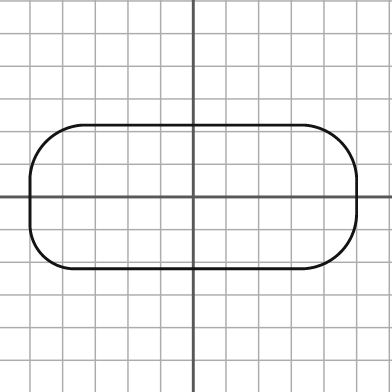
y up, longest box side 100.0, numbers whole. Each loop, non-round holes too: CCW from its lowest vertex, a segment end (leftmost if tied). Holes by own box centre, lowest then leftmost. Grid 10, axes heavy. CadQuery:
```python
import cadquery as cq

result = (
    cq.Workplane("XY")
    .moveTo(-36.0, -22.0)
    .lineTo(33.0, -22.0)
    .threePointArc((45.0, -17.0), (50.0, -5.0))
    .lineTo(50.0, 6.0)
    .threePointArc((45.0, 17.0), (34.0, 22.0))
    .lineTo(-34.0, 22.0)
    .threePointArc((-45.0, 17.0), (-50.0, 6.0))
    .lineTo(-50.0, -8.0)
    .threePointArc((-46.0, -18.0), (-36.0, -22.0))
    .close()
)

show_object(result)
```